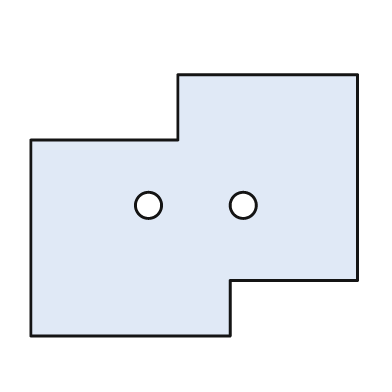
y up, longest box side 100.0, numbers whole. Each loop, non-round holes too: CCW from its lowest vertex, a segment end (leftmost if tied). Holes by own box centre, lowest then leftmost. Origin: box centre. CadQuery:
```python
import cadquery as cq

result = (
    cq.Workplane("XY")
    .moveTo(-50.0, -40.0)
    .lineTo(11.0, -40.0)
    .lineTo(11.0, -23.0)
    .lineTo(50.0, -23.0)
    .lineTo(50.0, 40.0)
    .lineTo(-5.0, 40.0)
    .lineTo(-5.0, 20.0)
    .lineTo(-50.0, 20.0)
    .close()
    .moveTo(-14.0, 0.0)
    .circle(4.0)
    .moveTo(15.0, 0.0)
    .circle(4.0)
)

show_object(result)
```